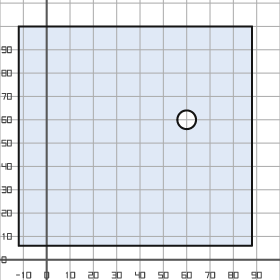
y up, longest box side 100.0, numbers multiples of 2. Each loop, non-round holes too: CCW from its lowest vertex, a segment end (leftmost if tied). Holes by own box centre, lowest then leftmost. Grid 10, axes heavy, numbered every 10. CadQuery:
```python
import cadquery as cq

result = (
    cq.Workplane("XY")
    .moveTo(-12.0, 6.0)
    .lineTo(88.0, 6.0)
    .lineTo(88.0, 100.0)
    .lineTo(-12.0, 100.0)
    .close()
    .moveTo(60.0, 60.0)
    .circle(4.0)
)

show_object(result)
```